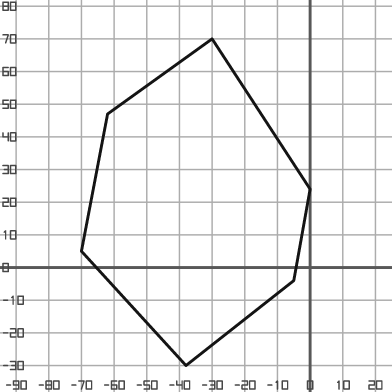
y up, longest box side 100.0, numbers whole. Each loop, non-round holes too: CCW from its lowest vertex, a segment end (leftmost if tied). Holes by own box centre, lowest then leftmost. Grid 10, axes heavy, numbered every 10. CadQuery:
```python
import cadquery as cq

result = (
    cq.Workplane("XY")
    .moveTo(-38.0, -30.0)
    .lineTo(-5.0, -4.0)
    .lineTo(0.0, 24.0)
    .lineTo(-30.0, 70.0)
    .lineTo(-62.0, 47.0)
    .lineTo(-70.0, 5.0)
    .close()
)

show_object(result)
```